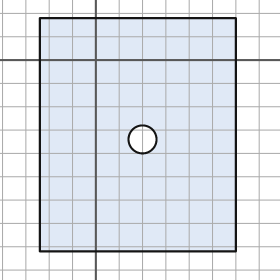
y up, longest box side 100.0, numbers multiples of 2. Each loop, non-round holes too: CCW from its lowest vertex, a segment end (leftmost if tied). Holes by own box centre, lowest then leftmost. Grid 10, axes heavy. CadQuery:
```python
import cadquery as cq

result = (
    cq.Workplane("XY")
    .moveTo(-24.0, -82.0)
    .lineTo(60.0, -82.0)
    .lineTo(60.0, 18.0)
    .lineTo(-24.0, 18.0)
    .close()
    .moveTo(20.0, -34.0)
    .circle(6.0)
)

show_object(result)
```